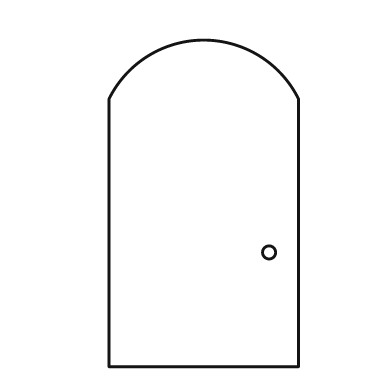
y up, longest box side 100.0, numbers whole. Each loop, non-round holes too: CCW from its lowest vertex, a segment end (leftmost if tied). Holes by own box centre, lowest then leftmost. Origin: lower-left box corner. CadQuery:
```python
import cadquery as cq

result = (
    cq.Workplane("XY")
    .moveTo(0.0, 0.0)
    .lineTo(58.0, 0.0)
    .lineTo(58.0, 82.0)
    .threePointArc((29.0, 100.0), (0.0, 82.0))
    .close()
    .moveTo(49.0, 35.0)
    .circle(2.0)
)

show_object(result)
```